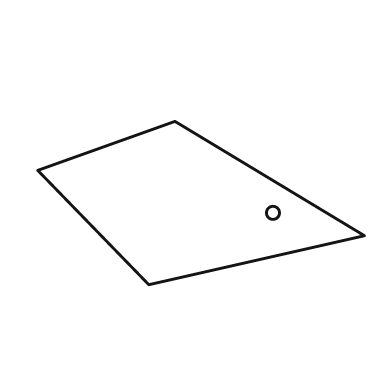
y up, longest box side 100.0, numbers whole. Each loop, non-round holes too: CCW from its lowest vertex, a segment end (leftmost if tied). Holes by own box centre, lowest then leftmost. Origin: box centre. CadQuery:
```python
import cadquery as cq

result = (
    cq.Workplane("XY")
    .moveTo(-16.0, -25.0)
    .lineTo(50.0, -10.0)
    .lineTo(-8.0, 25.0)
    .lineTo(-50.0, 10.0)
    .close()
    .moveTo(22.0, -3.0)
    .circle(2.0)
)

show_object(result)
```